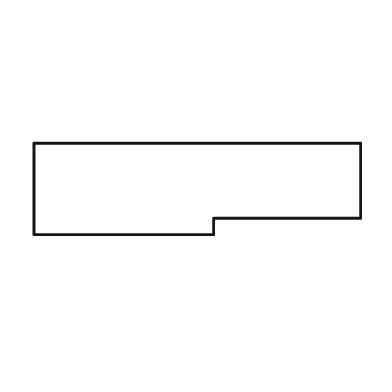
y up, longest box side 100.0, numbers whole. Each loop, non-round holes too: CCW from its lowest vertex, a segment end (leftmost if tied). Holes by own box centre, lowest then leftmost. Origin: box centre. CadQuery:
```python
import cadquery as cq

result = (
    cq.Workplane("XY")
    .moveTo(-50.0, -14.0)
    .lineTo(5.0, -14.0)
    .lineTo(5.0, -9.0)
    .lineTo(50.0, -9.0)
    .lineTo(50.0, 14.0)
    .lineTo(-50.0, 14.0)
    .close()
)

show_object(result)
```